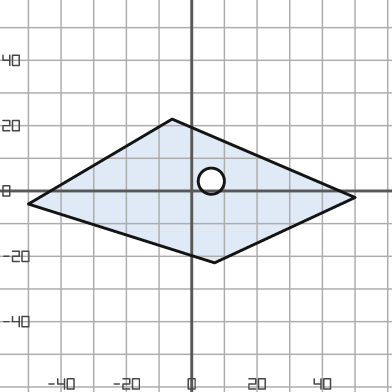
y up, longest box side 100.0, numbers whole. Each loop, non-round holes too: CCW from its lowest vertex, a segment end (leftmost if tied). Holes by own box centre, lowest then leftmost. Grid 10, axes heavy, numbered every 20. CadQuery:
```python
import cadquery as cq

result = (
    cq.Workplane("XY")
    .moveTo(7.0, -22.0)
    .lineTo(50.0, -2.0)
    .lineTo(-6.0, 22.0)
    .lineTo(-50.0, -4.0)
    .close()
    .moveTo(6.0, 3.0)
    .circle(4.0)
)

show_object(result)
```